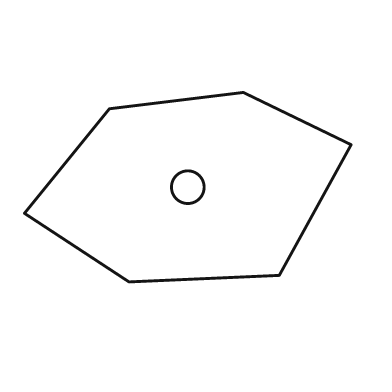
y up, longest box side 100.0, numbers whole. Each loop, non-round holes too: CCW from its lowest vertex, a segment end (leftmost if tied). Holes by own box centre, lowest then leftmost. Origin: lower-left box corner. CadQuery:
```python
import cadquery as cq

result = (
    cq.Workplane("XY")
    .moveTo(32.0, 0.0)
    .lineTo(78.0, 2.0)
    .lineTo(100.0, 42.0)
    .lineTo(67.0, 58.0)
    .lineTo(26.0, 53.0)
    .lineTo(0.0, 21.0)
    .close()
    .moveTo(50.0, 29.0)
    .circle(5.0)
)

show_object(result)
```